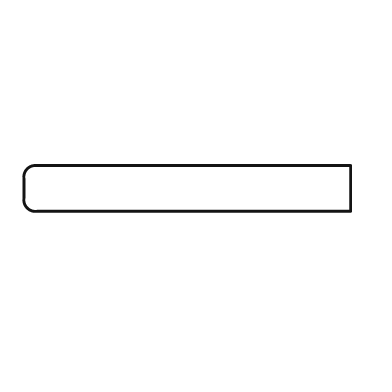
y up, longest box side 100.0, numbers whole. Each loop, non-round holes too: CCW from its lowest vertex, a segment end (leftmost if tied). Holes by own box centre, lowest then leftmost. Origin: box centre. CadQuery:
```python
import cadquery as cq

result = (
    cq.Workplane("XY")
    .moveTo(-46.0, -7.0)
    .lineTo(50.0, -7.0)
    .lineTo(50.0, 7.0)
    .lineTo(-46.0, 7.0)
    .threePointArc((-49.0, 6.0), (-50.0, 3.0))
    .lineTo(-50.0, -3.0)
    .threePointArc((-49.0, -6.0), (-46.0, -7.0))
    .close()
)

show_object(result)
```